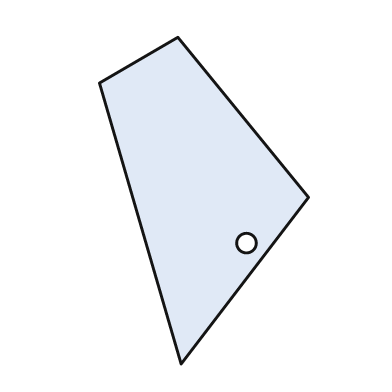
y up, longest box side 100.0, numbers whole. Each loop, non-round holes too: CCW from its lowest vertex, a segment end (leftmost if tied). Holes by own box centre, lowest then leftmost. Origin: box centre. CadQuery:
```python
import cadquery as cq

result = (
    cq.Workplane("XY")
    .moveTo(-7.0, -50.0)
    .lineTo(32.0, 1.0)
    .lineTo(-8.0, 50.0)
    .lineTo(-32.0, 36.0)
    .close()
    .moveTo(13.0, -13.0)
    .circle(3.0)
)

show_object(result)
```